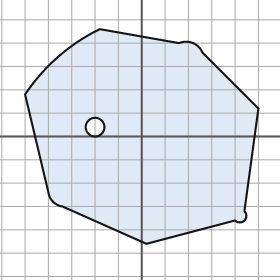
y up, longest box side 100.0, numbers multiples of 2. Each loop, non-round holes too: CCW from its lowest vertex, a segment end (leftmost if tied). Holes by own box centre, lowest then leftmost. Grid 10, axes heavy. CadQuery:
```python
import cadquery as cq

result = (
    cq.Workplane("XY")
    .moveTo(2.0, -46.0)
    .lineTo(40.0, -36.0)
    .threePointArc((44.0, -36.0), (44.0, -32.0))
    .lineTo(50.0, 12.0)
    .lineTo(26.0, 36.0)
    .threePointArc((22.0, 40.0), (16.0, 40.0))
    .lineTo(-18.0, 46.0)
    .threePointArc((-36.0, 34.0), (-50.0, 18.0))
    .lineTo(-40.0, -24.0)
    .threePointArc((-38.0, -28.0), (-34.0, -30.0))
    .close()
    .moveTo(-20.0, 4.0)
    .circle(4.0)
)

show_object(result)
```